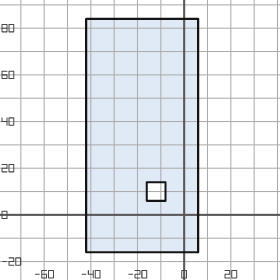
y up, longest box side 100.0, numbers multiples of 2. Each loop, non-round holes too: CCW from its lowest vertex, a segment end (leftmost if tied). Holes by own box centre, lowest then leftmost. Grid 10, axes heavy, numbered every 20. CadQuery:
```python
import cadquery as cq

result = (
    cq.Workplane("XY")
    .moveTo(-42.0, -16.0)
    .lineTo(6.0, -16.0)
    .lineTo(6.0, 84.0)
    .lineTo(-42.0, 84.0)
    .close()
    .moveTo(-16.0, 6.0)
    .lineTo(-8.0, 6.0)
    .lineTo(-8.0, 14.0)
    .lineTo(-16.0, 14.0)
    .close()
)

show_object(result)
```